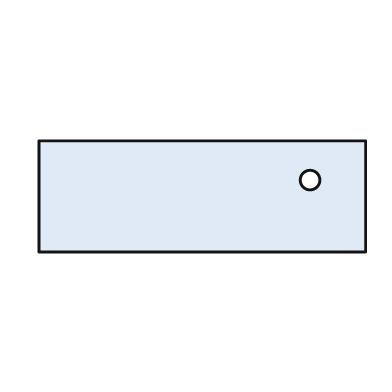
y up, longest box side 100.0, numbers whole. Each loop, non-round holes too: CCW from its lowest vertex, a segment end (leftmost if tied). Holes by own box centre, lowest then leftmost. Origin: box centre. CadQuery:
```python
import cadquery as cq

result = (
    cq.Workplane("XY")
    .moveTo(-50.0, -17.0)
    .lineTo(50.0, -17.0)
    .lineTo(50.0, 17.0)
    .lineTo(-50.0, 17.0)
    .close()
    .moveTo(33.0, 5.0)
    .circle(3.0)
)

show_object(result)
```